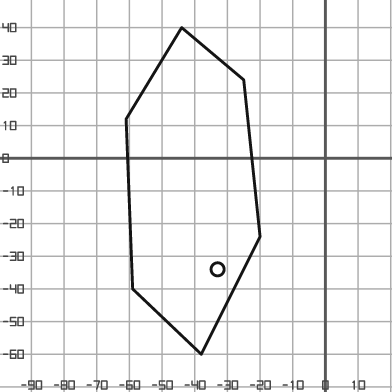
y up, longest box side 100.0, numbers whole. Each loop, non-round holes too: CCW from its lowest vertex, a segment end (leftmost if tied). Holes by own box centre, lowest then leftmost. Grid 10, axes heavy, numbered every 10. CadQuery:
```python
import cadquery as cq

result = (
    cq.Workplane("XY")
    .moveTo(-38.0, -60.0)
    .lineTo(-20.0, -24.0)
    .lineTo(-25.0, 24.0)
    .lineTo(-44.0, 40.0)
    .lineTo(-61.0, 12.0)
    .lineTo(-59.0, -40.0)
    .close()
    .moveTo(-33.0, -34.0)
    .circle(2.0)
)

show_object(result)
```